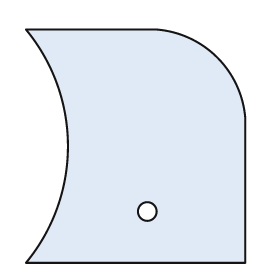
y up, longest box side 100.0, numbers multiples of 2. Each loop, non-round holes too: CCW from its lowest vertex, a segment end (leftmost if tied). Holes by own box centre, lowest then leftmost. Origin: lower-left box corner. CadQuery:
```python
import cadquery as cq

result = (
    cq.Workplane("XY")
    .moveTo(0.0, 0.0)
    .lineTo(94.0, 0.0)
    .lineTo(94.0, 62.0)
    .threePointArc((82.0, 88.0), (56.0, 100.0))
    .lineTo(0.0, 100.0)
    .threePointArc((18.0, 50.0), (0.0, 0.0))
    .close()
    .moveTo(52.0, 22.0)
    .circle(4.0)
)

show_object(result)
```